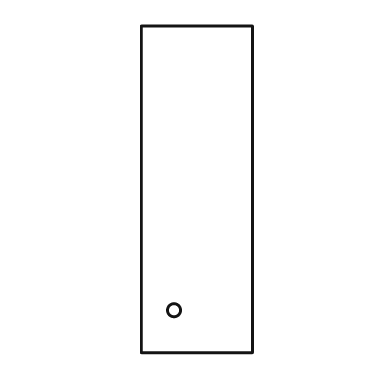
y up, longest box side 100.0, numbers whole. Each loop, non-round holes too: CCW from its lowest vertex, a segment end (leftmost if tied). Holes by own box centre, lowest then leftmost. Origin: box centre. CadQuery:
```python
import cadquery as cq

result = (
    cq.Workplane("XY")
    .moveTo(-17.0, -50.0)
    .lineTo(17.0, -50.0)
    .lineTo(17.0, 50.0)
    .lineTo(-17.0, 50.0)
    .close()
    .moveTo(-7.0, -37.0)
    .circle(2.0)
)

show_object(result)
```